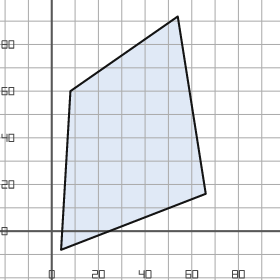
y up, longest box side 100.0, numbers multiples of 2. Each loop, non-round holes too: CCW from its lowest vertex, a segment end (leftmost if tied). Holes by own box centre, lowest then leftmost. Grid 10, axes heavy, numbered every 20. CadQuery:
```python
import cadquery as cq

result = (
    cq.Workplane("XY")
    .moveTo(4.0, -8.0)
    .lineTo(66.0, 16.0)
    .lineTo(54.0, 92.0)
    .lineTo(8.0, 60.0)
    .close()
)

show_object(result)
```